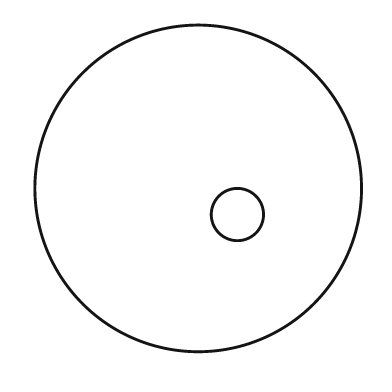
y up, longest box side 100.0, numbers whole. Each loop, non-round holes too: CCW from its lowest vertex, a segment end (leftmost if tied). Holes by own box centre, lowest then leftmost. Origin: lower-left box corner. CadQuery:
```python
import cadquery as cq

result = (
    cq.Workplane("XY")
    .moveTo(50.0, 50.0)
    .circle(50.0)
    .moveTo(62.0, 42.0)
    .circle(8.0)
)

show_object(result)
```